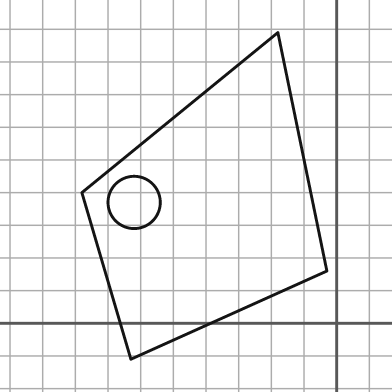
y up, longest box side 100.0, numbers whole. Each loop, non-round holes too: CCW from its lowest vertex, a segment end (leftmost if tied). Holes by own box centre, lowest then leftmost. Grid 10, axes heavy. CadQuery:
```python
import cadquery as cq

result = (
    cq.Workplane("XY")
    .moveTo(-63.0, -11.0)
    .lineTo(-3.0, 16.0)
    .lineTo(-18.0, 89.0)
    .lineTo(-78.0, 40.0)
    .close()
    .moveTo(-62.0, 37.0)
    .circle(8.0)
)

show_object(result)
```